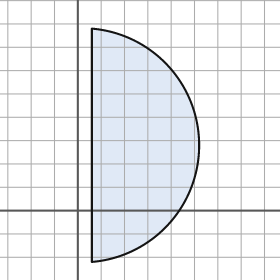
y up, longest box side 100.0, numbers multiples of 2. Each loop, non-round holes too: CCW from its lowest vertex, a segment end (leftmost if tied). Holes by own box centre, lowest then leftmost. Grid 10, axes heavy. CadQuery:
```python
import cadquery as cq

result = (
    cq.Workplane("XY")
    .moveTo(6.0, -22.0)
    .threePointArc((52.0, 28.0), (6.0, 78.0))
    .close()
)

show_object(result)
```